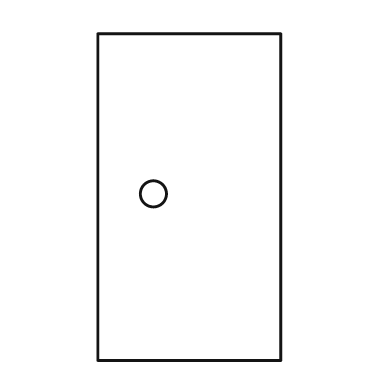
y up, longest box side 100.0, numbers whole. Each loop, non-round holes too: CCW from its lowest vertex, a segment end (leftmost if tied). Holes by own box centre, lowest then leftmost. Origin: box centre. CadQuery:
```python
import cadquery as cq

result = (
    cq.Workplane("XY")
    .moveTo(-28.0, -50.0)
    .lineTo(28.0, -50.0)
    .lineTo(28.0, 50.0)
    .lineTo(-28.0, 50.0)
    .close()
    .moveTo(-11.0, 1.0)
    .circle(4.0)
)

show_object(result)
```